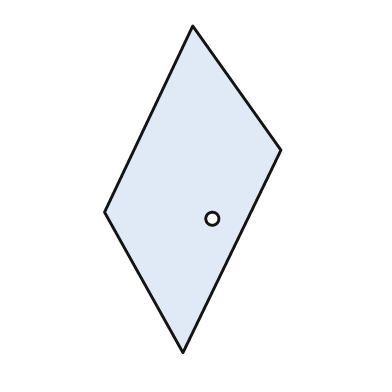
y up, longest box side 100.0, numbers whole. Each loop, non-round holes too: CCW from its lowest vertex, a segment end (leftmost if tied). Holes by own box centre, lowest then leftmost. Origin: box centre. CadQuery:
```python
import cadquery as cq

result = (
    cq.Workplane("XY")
    .moveTo(-3.0, -50.0)
    .lineTo(27.0, 12.0)
    .lineTo(0.0, 50.0)
    .lineTo(-27.0, -7.0)
    .close()
    .moveTo(6.0, -9.0)
    .circle(2.0)
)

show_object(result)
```